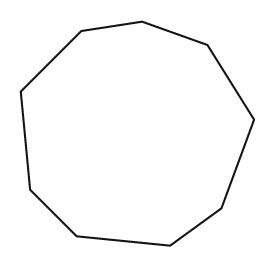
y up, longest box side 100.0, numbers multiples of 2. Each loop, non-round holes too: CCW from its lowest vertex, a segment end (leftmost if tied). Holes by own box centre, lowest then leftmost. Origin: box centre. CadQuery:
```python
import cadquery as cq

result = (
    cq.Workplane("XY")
    .moveTo(14.0, -48.0)
    .lineTo(36.0, -32.0)
    .lineTo(50.0, 6.0)
    .lineTo(30.0, 38.0)
    .lineTo(2.0, 48.0)
    .lineTo(-24.0, 44.0)
    .lineTo(-50.0, 18.0)
    .lineTo(-46.0, -24.0)
    .lineTo(-26.0, -44.0)
    .close()
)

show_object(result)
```